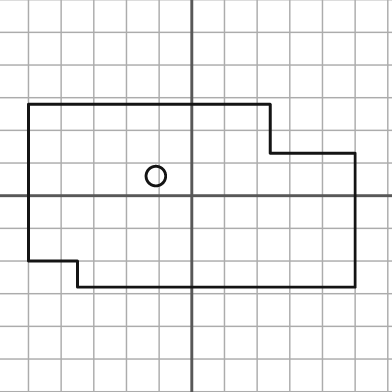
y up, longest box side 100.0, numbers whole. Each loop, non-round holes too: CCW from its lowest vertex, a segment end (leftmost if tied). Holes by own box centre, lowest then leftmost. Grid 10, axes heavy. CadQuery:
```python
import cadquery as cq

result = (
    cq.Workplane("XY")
    .moveTo(-35.0, -28.0)
    .lineTo(50.0, -28.0)
    .lineTo(50.0, 13.0)
    .lineTo(24.0, 13.0)
    .lineTo(24.0, 28.0)
    .lineTo(-50.0, 28.0)
    .lineTo(-50.0, -20.0)
    .lineTo(-35.0, -20.0)
    .close()
    .moveTo(-11.0, 6.0)
    .circle(3.0)
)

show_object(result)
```